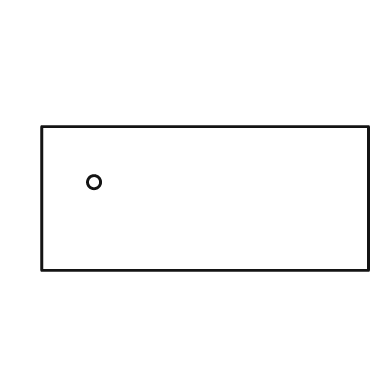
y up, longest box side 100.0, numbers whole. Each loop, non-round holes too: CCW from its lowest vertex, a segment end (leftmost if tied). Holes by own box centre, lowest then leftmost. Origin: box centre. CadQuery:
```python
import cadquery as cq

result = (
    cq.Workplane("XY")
    .moveTo(-50.0, -22.0)
    .lineTo(50.0, -22.0)
    .lineTo(50.0, 22.0)
    .lineTo(-50.0, 22.0)
    .close()
    .moveTo(-34.0, 5.0)
    .circle(2.0)
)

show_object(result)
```